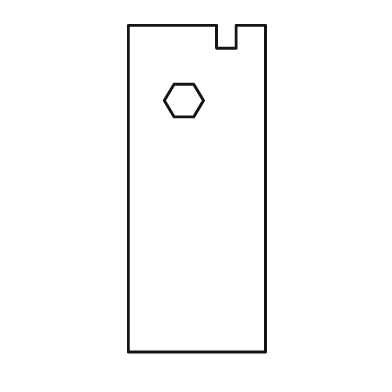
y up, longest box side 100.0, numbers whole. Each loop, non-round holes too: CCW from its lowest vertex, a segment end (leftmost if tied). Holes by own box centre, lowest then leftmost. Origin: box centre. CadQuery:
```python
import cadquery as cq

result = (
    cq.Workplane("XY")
    .moveTo(-21.0, -50.0)
    .lineTo(21.0, -50.0)
    .lineTo(21.0, 50.0)
    .lineTo(12.0, 50.0)
    .lineTo(12.0, 43.0)
    .lineTo(6.0, 43.0)
    .lineTo(6.0, 50.0)
    .lineTo(-21.0, 50.0)
    .close()
    .moveTo(-7.0, 22.0)
    .lineTo(-1.0, 22.0)
    .lineTo(2.0, 27.0)
    .lineTo(-1.0, 32.0)
    .lineTo(-7.0, 32.0)
    .lineTo(-10.0, 27.0)
    .close()
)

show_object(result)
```